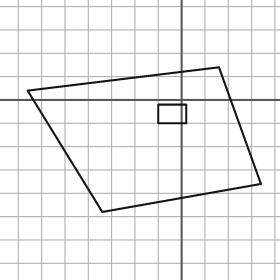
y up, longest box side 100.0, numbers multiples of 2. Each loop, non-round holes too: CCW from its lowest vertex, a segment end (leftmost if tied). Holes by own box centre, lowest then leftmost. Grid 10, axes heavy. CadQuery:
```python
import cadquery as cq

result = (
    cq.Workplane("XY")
    .moveTo(-34.0, -48.0)
    .lineTo(34.0, -36.0)
    .lineTo(16.0, 14.0)
    .lineTo(-66.0, 4.0)
    .close()
    .moveTo(-10.0, -10.0)
    .lineTo(2.0, -10.0)
    .lineTo(2.0, -2.0)
    .lineTo(-10.0, -2.0)
    .close()
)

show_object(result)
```